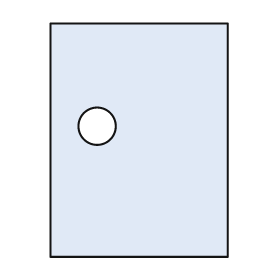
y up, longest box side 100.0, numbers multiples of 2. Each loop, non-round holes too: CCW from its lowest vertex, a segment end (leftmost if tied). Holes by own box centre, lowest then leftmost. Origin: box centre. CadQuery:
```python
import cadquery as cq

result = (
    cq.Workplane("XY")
    .moveTo(-38.0, -50.0)
    .lineTo(38.0, -50.0)
    .lineTo(38.0, 50.0)
    .lineTo(-38.0, 50.0)
    .close()
    .moveTo(-18.0, 6.0)
    .circle(8.0)
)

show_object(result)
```